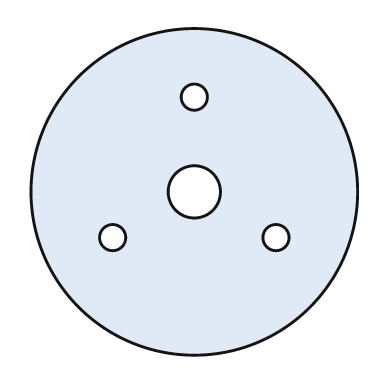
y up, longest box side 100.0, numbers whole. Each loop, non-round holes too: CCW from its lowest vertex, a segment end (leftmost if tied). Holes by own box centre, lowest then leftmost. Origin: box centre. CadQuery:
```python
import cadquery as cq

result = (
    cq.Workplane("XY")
    .moveTo(0.0, 0.0)
    .circle(50.0)
    .moveTo(-25.0, -14.0)
    .circle(4.0)
    .moveTo(25.0, -14.0)
    .circle(4.0)
    .moveTo(0.0, 0.0)
    .circle(8.0)
    .moveTo(0.0, 29.0)
    .circle(4.0)
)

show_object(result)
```